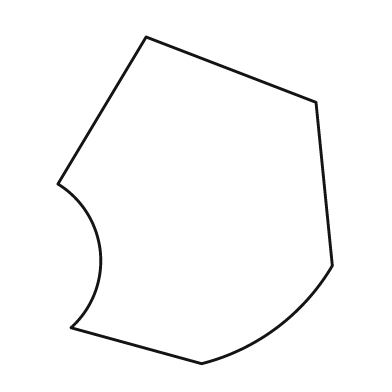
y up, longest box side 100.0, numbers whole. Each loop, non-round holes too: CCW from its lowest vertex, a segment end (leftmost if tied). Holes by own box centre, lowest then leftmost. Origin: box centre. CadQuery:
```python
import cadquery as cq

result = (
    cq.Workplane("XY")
    .moveTo(2.0, -50.0)
    .threePointArc((25.0, -39.0), (42.0, -20.0))
    .lineTo(37.0, 30.0)
    .lineTo(-15.0, 50.0)
    .lineTo(-42.0, 5.0)
    .threePointArc((-29.0, -16.0), (-38.0, -39.0))
    .close()
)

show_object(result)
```